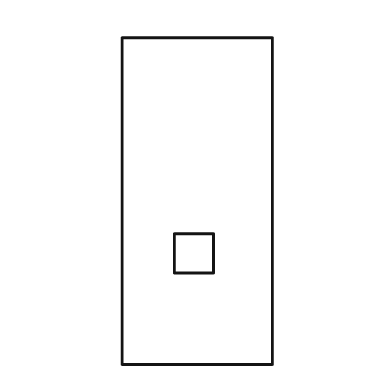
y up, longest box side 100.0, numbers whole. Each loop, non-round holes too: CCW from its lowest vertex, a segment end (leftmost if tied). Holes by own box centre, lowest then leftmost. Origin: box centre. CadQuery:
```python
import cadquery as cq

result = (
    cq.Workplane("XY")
    .moveTo(-23.0, -50.0)
    .lineTo(23.0, -50.0)
    .lineTo(23.0, 50.0)
    .lineTo(-23.0, 50.0)
    .close()
    .moveTo(-7.0, -22.0)
    .lineTo(5.0, -22.0)
    .lineTo(5.0, -10.0)
    .lineTo(-7.0, -10.0)
    .close()
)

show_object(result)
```